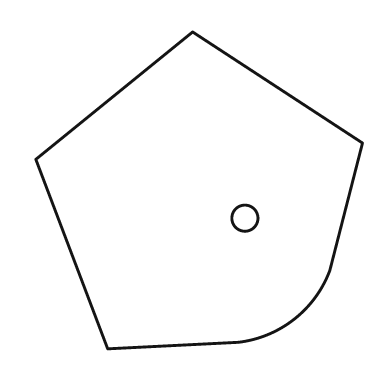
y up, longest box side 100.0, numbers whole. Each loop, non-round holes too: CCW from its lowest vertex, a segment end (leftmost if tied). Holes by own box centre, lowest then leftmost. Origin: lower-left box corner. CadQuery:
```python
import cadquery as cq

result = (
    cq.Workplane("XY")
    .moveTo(22.0, 0.0)
    .lineTo(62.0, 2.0)
    .threePointArc((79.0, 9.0), (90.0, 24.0))
    .lineTo(100.0, 63.0)
    .lineTo(48.0, 97.0)
    .lineTo(0.0, 58.0)
    .close()
    .moveTo(64.0, 40.0)
    .circle(4.0)
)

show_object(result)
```